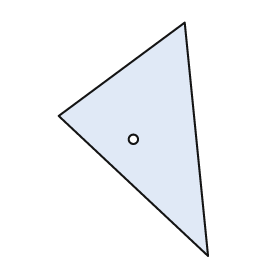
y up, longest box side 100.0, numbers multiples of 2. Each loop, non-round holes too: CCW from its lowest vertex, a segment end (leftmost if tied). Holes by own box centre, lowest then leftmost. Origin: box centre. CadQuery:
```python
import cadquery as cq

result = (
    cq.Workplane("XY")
    .moveTo(32.0, -50.0)
    .lineTo(22.0, 50.0)
    .lineTo(-32.0, 10.0)
    .close()
    .moveTo(0.0, 0.0)
    .circle(2.0)
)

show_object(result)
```